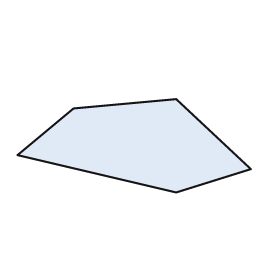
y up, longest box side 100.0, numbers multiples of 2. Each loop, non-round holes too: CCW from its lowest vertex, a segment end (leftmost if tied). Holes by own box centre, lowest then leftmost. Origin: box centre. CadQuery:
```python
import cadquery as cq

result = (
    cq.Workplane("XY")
    .moveTo(18.0, -20.0)
    .lineTo(50.0, -10.0)
    .lineTo(18.0, 20.0)
    .lineTo(-26.0, 16.0)
    .lineTo(-50.0, -4.0)
    .close()
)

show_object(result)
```